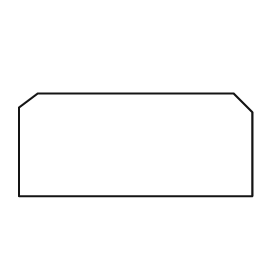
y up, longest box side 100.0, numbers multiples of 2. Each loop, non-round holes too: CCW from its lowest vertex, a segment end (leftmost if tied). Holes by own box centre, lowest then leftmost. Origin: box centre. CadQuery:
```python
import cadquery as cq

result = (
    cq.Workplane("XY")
    .moveTo(-50.0, -22.0)
    .lineTo(50.0, -22.0)
    .lineTo(50.0, 14.0)
    .lineTo(42.0, 22.0)
    .lineTo(-42.0, 22.0)
    .lineTo(-50.0, 16.0)
    .close()
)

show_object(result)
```